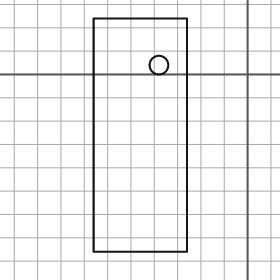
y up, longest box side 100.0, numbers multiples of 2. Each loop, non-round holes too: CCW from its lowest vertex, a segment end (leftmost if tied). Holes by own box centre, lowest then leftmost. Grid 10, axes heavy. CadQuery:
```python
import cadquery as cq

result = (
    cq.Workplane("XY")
    .moveTo(-66.0, -76.0)
    .lineTo(-26.0, -76.0)
    .lineTo(-26.0, 24.0)
    .lineTo(-66.0, 24.0)
    .close()
    .moveTo(-38.0, 4.0)
    .circle(4.0)
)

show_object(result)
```